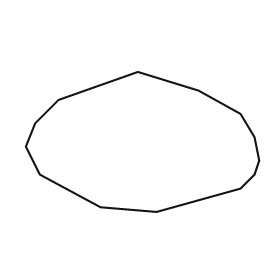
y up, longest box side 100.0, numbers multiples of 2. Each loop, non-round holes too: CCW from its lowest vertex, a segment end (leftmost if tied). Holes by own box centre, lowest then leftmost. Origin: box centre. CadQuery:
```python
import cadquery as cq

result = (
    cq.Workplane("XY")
    .moveTo(6.0, -30.0)
    .lineTo(42.0, -20.0)
    .lineTo(48.0, -14.0)
    .lineTo(50.0, -8.0)
    .lineTo(48.0, 2.0)
    .lineTo(42.0, 12.0)
    .lineTo(24.0, 22.0)
    .lineTo(-2.0, 30.0)
    .lineTo(-36.0, 18.0)
    .lineTo(-46.0, 8.0)
    .lineTo(-50.0, -2.0)
    .lineTo(-44.0, -14.0)
    .lineTo(-18.0, -28.0)
    .close()
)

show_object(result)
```